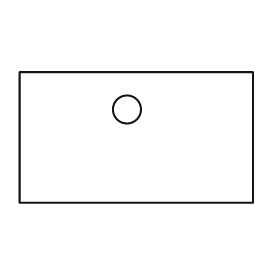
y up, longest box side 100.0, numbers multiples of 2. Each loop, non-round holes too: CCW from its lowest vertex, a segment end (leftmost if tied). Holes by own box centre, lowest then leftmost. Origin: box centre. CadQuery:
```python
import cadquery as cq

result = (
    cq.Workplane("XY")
    .moveTo(-50.0, -28.0)
    .lineTo(50.0, -28.0)
    .lineTo(50.0, 28.0)
    .lineTo(-50.0, 28.0)
    .close()
    .moveTo(-4.0, 12.0)
    .circle(6.0)
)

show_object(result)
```